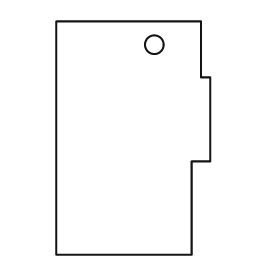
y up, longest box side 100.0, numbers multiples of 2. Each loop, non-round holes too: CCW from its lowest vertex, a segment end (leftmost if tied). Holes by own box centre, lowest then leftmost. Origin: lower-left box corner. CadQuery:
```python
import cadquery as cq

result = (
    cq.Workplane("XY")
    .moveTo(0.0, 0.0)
    .lineTo(58.0, 0.0)
    .lineTo(58.0, 40.0)
    .lineTo(66.0, 40.0)
    .lineTo(66.0, 76.0)
    .lineTo(62.0, 76.0)
    .lineTo(62.0, 100.0)
    .lineTo(0.0, 100.0)
    .close()
    .moveTo(42.0, 90.0)
    .circle(4.0)
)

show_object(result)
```